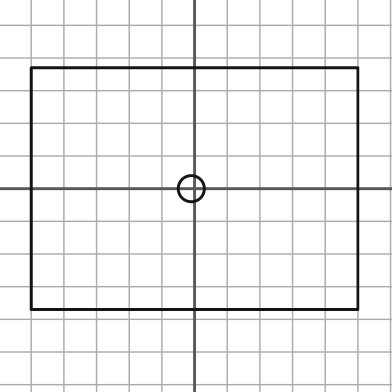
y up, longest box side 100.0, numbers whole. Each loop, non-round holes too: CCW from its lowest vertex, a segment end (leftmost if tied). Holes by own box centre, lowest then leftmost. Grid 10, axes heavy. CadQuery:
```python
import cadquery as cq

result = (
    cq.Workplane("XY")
    .moveTo(-50.0, -37.0)
    .lineTo(50.0, -37.0)
    .lineTo(50.0, 37.0)
    .lineTo(-50.0, 37.0)
    .close()
    .moveTo(-1.0, 0.0)
    .circle(4.0)
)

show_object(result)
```